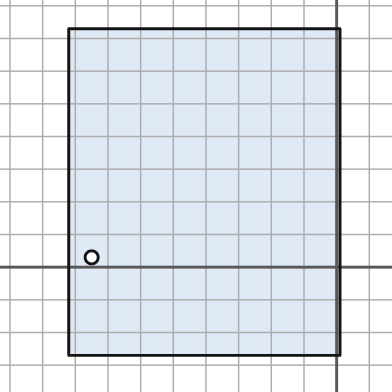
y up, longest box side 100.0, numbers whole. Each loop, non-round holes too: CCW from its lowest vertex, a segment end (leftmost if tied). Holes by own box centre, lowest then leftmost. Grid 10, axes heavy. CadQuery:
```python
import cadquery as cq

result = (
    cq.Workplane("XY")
    .moveTo(-82.0, -27.0)
    .lineTo(1.0, -27.0)
    .lineTo(1.0, 73.0)
    .lineTo(-82.0, 73.0)
    .close()
    .moveTo(-75.0, 3.0)
    .circle(2.0)
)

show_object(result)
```